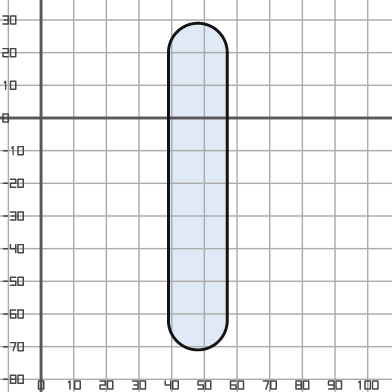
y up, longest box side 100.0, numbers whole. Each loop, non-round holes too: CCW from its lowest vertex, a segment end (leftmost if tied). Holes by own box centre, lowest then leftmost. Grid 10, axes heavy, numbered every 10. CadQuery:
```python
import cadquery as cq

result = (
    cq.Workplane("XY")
    .moveTo(39.0, -62.0)
    .threePointArc((48.0, -71.0), (57.0, -62.0))
    .lineTo(57.0, 20.0)
    .threePointArc((48.0, 29.0), (39.0, 20.0))
    .close()
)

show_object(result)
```